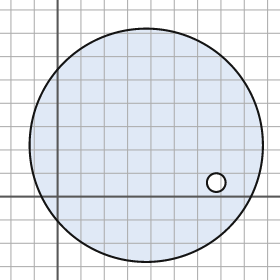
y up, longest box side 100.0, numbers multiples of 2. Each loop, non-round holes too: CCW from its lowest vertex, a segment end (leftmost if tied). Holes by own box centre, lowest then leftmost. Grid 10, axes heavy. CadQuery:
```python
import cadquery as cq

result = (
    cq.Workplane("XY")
    .moveTo(38.0, 22.0)
    .circle(50.0)
    .moveTo(68.0, 6.0)
    .circle(4.0)
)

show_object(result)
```